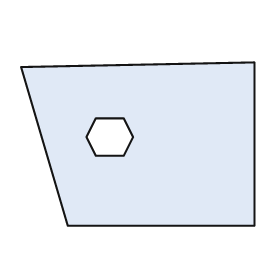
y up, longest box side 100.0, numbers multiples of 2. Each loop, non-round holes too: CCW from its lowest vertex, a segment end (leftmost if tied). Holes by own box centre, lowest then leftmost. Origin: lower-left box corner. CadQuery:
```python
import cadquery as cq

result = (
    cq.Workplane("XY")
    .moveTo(20.0, 0.0)
    .lineTo(100.0, 0.0)
    .lineTo(100.0, 70.0)
    .lineTo(0.0, 68.0)
    .close()
    .moveTo(32.0, 30.0)
    .lineTo(44.0, 30.0)
    .lineTo(48.0, 38.0)
    .lineTo(44.0, 46.0)
    .lineTo(32.0, 46.0)
    .lineTo(28.0, 38.0)
    .close()
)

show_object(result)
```